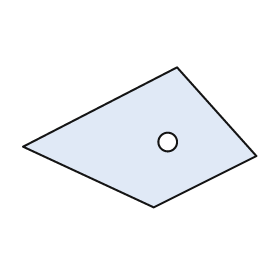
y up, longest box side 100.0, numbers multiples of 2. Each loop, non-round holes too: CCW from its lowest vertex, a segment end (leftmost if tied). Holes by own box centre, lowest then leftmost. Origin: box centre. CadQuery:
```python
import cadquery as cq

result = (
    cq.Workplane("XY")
    .moveTo(6.0, -30.0)
    .lineTo(50.0, -8.0)
    .lineTo(16.0, 30.0)
    .lineTo(-50.0, -4.0)
    .close()
    .moveTo(12.0, -2.0)
    .circle(4.0)
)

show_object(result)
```